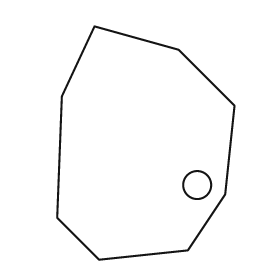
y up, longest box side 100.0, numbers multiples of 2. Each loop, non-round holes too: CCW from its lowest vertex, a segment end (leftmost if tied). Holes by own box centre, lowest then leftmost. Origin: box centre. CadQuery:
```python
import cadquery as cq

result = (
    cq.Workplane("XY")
    .moveTo(-20.0, -50.0)
    .lineTo(18.0, -46.0)
    .lineTo(34.0, -22.0)
    .lineTo(38.0, 16.0)
    .lineTo(14.0, 40.0)
    .lineTo(-22.0, 50.0)
    .lineTo(-36.0, 20.0)
    .lineTo(-38.0, -32.0)
    .close()
    .moveTo(22.0, -18.0)
    .circle(6.0)
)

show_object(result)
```